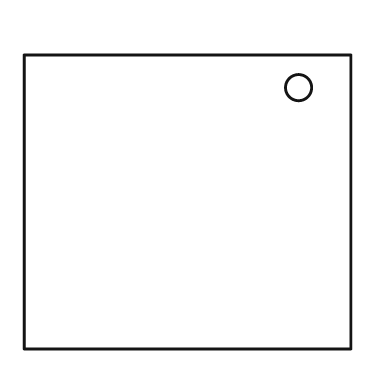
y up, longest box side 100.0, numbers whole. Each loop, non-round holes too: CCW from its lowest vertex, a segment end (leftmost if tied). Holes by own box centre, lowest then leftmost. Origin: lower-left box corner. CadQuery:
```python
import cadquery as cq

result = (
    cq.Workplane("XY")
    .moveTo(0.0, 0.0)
    .lineTo(100.0, 0.0)
    .lineTo(100.0, 90.0)
    .lineTo(0.0, 90.0)
    .close()
    .moveTo(84.0, 80.0)
    .circle(4.0)
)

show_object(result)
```